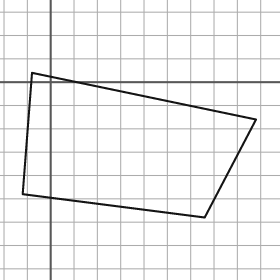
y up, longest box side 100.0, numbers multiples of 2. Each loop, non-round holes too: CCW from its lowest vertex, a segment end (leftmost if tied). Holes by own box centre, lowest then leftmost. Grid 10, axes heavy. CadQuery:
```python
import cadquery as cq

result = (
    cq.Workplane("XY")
    .moveTo(66.0, -58.0)
    .lineTo(88.0, -16.0)
    .lineTo(-8.0, 4.0)
    .lineTo(-12.0, -48.0)
    .close()
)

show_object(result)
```